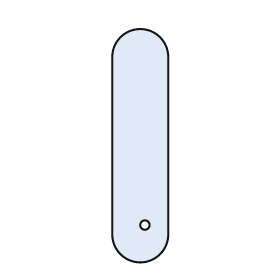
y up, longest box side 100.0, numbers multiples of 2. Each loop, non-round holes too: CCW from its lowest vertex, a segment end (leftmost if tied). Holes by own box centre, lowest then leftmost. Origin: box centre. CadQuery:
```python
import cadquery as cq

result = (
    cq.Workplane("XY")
    .moveTo(-12.0, -38.0)
    .threePointArc((0.0, -50.0), (12.0, -38.0))
    .lineTo(12.0, 38.0)
    .threePointArc((0.0, 50.0), (-12.0, 38.0))
    .close()
    .moveTo(2.0, -34.0)
    .circle(2.0)
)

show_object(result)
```